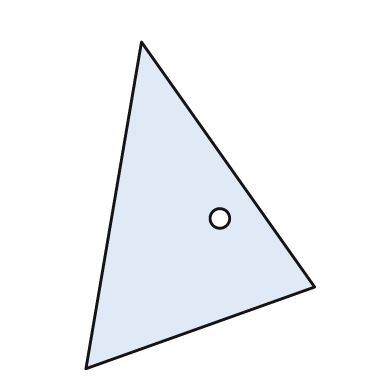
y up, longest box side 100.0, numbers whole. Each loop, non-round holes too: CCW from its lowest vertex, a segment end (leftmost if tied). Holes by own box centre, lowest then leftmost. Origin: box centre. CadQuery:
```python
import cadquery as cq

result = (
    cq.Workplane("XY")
    .moveTo(-35.0, -50.0)
    .lineTo(35.0, -25.0)
    .lineTo(-18.0, 50.0)
    .close()
    .moveTo(6.0, -4.0)
    .circle(3.0)
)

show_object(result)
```